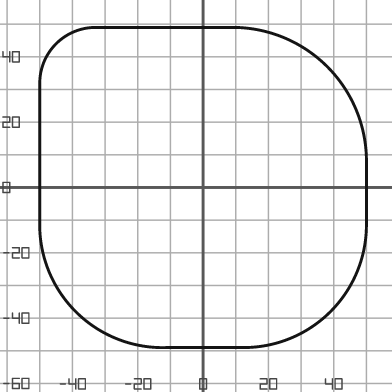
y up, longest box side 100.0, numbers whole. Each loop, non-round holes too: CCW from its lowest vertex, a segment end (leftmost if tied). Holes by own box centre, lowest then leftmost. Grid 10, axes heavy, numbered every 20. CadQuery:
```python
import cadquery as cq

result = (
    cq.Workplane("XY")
    .moveTo(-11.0, -49.0)
    .lineTo(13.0, -49.0)
    .threePointArc((39.0, -38.0), (50.0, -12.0))
    .lineTo(50.0, 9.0)
    .threePointArc((38.0, 37.0), (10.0, 49.0))
    .lineTo(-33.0, 49.0)
    .threePointArc((-45.0, 44.0), (-50.0, 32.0))
    .lineTo(-50.0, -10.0)
    .threePointArc((-39.0, -38.0), (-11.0, -49.0))
    .close()
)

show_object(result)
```